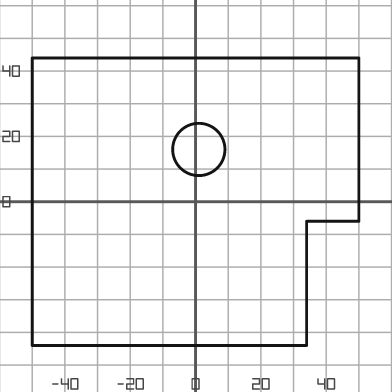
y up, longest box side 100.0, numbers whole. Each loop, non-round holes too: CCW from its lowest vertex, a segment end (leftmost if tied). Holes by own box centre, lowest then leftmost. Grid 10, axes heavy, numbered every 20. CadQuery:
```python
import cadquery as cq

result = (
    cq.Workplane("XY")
    .moveTo(-50.0, -44.0)
    .lineTo(34.0, -44.0)
    .lineTo(34.0, -6.0)
    .lineTo(50.0, -6.0)
    .lineTo(50.0, 44.0)
    .lineTo(-50.0, 44.0)
    .close()
    .moveTo(1.0, 16.0)
    .circle(8.0)
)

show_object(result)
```